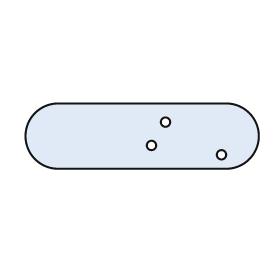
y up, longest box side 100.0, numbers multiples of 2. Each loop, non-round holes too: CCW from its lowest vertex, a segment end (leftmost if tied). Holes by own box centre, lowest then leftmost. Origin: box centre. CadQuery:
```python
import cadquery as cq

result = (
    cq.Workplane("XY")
    .moveTo(-36.0, -14.0)
    .lineTo(36.0, -14.0)
    .threePointArc((50.0, 0.0), (36.0, 14.0))
    .lineTo(-36.0, 14.0)
    .threePointArc((-50.0, 0.0), (-36.0, -14.0))
    .close()
    .moveTo(34.0, -8.0)
    .circle(2.0)
    .moveTo(4.0, -4.0)
    .circle(2.0)
    .moveTo(10.0, 6.0)
    .circle(2.0)
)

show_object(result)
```